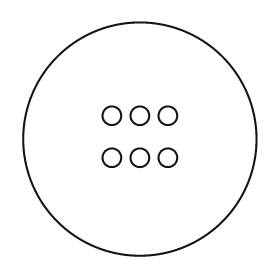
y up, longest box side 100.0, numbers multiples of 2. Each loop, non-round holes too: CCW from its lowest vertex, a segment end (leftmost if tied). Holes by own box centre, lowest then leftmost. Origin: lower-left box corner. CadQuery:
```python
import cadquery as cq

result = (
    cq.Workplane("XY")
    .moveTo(50.0, 50.0)
    .circle(50.0)
    .moveTo(38.0, 42.0)
    .circle(4.0)
    .moveTo(50.0, 42.0)
    .circle(4.0)
    .moveTo(62.0, 42.0)
    .circle(4.0)
    .moveTo(38.0, 60.0)
    .circle(4.0)
    .moveTo(50.0, 60.0)
    .circle(4.0)
    .moveTo(62.0, 60.0)
    .circle(4.0)
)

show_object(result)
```